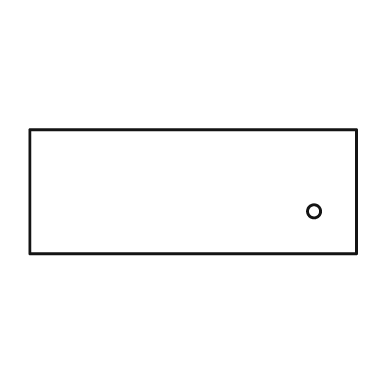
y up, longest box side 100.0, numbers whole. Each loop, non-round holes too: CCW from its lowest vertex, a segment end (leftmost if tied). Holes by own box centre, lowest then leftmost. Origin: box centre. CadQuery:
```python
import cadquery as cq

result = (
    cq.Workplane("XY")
    .moveTo(-50.0, -19.0)
    .lineTo(50.0, -19.0)
    .lineTo(50.0, 19.0)
    .lineTo(-50.0, 19.0)
    .close()
    .moveTo(37.0, -6.0)
    .circle(2.0)
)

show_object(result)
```